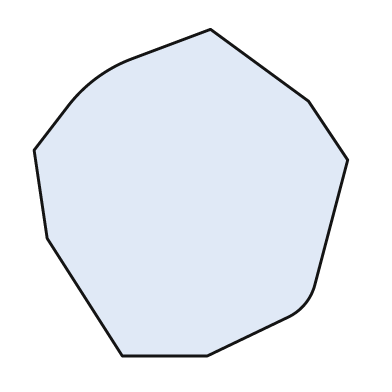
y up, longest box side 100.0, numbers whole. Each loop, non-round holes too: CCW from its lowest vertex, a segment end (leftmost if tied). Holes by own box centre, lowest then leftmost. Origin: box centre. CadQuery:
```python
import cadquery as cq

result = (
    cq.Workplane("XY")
    .moveTo(-21.0, -50.0)
    .lineTo(5.0, -50.0)
    .lineTo(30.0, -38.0)
    .threePointArc((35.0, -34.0), (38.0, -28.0))
    .lineTo(48.0, 10.0)
    .lineTo(36.0, 28.0)
    .lineTo(6.0, 50.0)
    .lineTo(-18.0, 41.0)
    .threePointArc((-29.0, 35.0), (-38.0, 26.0))
    .lineTo(-48.0, 13.0)
    .lineTo(-44.0, -14.0)
    .close()
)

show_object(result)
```